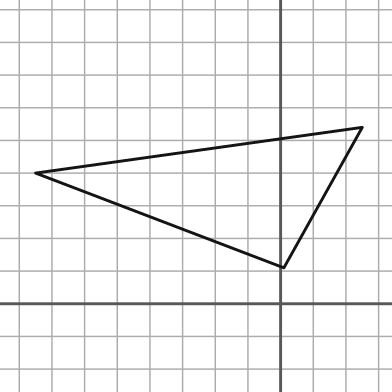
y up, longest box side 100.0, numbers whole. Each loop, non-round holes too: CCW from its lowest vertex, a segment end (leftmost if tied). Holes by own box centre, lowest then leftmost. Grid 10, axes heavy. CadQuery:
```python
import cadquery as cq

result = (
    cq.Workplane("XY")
    .moveTo(1.0, 11.0)
    .lineTo(25.0, 54.0)
    .lineTo(-75.0, 40.0)
    .close()
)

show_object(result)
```